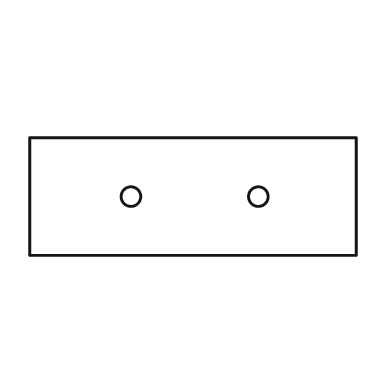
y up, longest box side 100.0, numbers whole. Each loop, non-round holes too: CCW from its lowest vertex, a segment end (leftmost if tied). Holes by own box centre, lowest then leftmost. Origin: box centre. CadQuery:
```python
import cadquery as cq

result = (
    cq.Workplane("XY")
    .moveTo(-50.0, -18.0)
    .lineTo(50.0, -18.0)
    .lineTo(50.0, 18.0)
    .lineTo(-50.0, 18.0)
    .close()
    .moveTo(-19.0, 0.0)
    .circle(3.0)
    .moveTo(20.0, 0.0)
    .circle(3.0)
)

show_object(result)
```